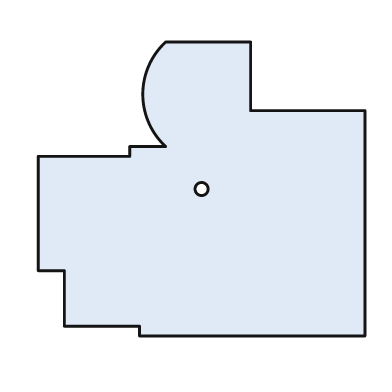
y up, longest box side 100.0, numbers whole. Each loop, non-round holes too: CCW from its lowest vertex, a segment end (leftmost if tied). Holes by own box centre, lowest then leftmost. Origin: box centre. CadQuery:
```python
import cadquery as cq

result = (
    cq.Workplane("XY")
    .moveTo(-19.0, -45.0)
    .lineTo(50.0, -45.0)
    .lineTo(50.0, 24.0)
    .lineTo(15.0, 24.0)
    .lineTo(15.0, 45.0)
    .lineTo(-11.0, 45.0)
    .threePointArc((-18.0, 29.0), (-11.0, 13.0))
    .lineTo(-22.0, 13.0)
    .lineTo(-22.0, 10.0)
    .lineTo(-50.0, 10.0)
    .lineTo(-50.0, -25.0)
    .lineTo(-42.0, -25.0)
    .lineTo(-42.0, -42.0)
    .lineTo(-19.0, -42.0)
    .close()
    .moveTo(0.0, 0.0)
    .circle(2.0)
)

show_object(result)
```